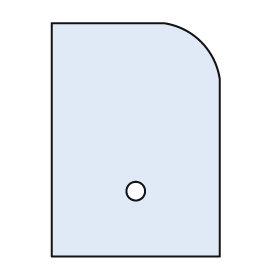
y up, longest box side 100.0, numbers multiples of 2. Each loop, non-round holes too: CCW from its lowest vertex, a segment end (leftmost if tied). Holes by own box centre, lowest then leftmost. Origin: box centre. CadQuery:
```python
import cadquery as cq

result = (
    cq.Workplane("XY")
    .moveTo(-36.0, -50.0)
    .lineTo(36.0, -50.0)
    .lineTo(36.0, 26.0)
    .threePointArc((28.0, 42.0), (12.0, 50.0))
    .lineTo(-36.0, 50.0)
    .close()
    .moveTo(0.0, -22.0)
    .circle(4.0)
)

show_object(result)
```